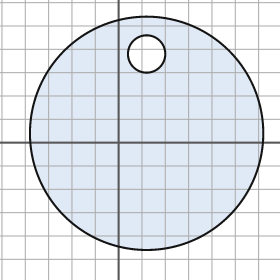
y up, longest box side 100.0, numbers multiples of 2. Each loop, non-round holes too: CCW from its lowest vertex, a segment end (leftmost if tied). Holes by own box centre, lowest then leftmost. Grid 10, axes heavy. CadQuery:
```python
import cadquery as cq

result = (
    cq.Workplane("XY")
    .moveTo(12.0, 4.0)
    .circle(50.0)
    .moveTo(12.0, 38.0)
    .circle(8.0)
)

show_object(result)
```